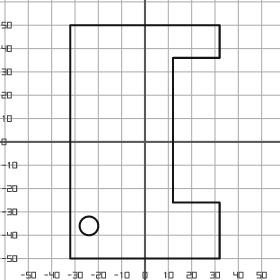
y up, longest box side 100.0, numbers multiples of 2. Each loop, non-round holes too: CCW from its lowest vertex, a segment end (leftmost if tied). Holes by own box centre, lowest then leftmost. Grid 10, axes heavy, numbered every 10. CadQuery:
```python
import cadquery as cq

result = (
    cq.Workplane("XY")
    .moveTo(-32.0, -50.0)
    .lineTo(32.0, -50.0)
    .lineTo(32.0, -26.0)
    .lineTo(12.0, -26.0)
    .lineTo(12.0, 36.0)
    .lineTo(32.0, 36.0)
    .lineTo(32.0, 50.0)
    .lineTo(-32.0, 50.0)
    .close()
    .moveTo(-24.0, -36.0)
    .circle(4.0)
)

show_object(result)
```